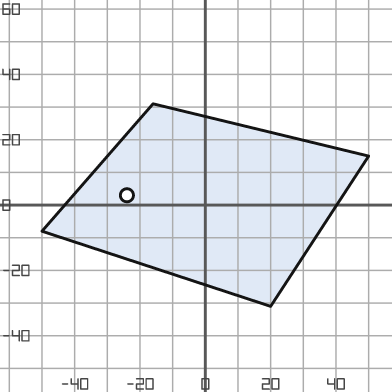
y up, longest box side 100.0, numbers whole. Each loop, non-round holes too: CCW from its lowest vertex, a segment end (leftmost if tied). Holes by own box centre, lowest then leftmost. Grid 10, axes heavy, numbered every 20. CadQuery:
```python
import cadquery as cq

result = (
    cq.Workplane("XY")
    .moveTo(20.0, -31.0)
    .lineTo(50.0, 15.0)
    .lineTo(-16.0, 31.0)
    .lineTo(-50.0, -8.0)
    .close()
    .moveTo(-24.0, 3.0)
    .circle(2.0)
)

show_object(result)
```